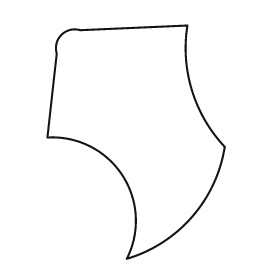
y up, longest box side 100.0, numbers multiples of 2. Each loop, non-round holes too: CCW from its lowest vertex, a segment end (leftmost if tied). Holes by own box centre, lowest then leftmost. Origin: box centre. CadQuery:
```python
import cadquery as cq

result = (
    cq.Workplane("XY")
    .moveTo(-4.0, -50.0)
    .threePointArc((24.0, -32.0), (38.0, -2.0))
    .threePointArc((24.0, 22.0), (22.0, 50.0))
    .lineTo(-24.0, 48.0)
    .threePointArc((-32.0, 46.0), (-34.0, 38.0))
    .lineTo(-38.0, 2.0)
    .threePointArc((-6.0, -14.0), (-4.0, -50.0))
    .close()
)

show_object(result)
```